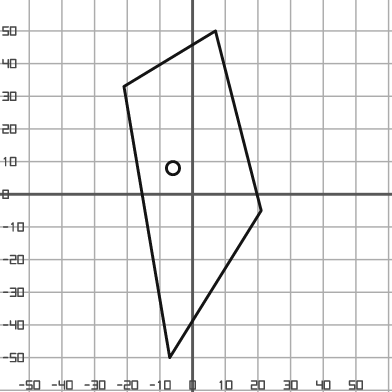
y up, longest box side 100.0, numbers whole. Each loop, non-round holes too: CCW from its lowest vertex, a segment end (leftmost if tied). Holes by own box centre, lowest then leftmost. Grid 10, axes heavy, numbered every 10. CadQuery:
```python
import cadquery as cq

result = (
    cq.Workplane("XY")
    .moveTo(-7.0, -50.0)
    .lineTo(21.0, -5.0)
    .lineTo(7.0, 50.0)
    .lineTo(-21.0, 33.0)
    .close()
    .moveTo(-6.0, 8.0)
    .circle(2.0)
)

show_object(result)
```